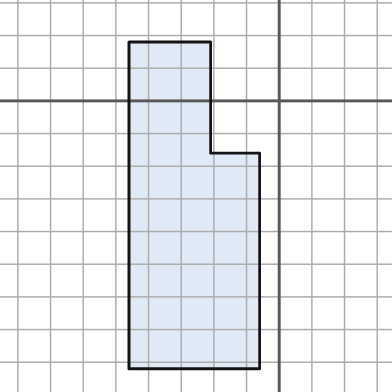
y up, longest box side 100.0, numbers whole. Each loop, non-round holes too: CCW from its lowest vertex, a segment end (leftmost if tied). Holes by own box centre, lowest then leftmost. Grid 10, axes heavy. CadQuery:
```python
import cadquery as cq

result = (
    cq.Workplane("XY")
    .moveTo(-46.0, -82.0)
    .lineTo(-6.0, -82.0)
    .lineTo(-6.0, -16.0)
    .lineTo(-21.0, -16.0)
    .lineTo(-21.0, 18.0)
    .lineTo(-46.0, 18.0)
    .close()
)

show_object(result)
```